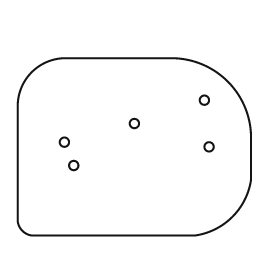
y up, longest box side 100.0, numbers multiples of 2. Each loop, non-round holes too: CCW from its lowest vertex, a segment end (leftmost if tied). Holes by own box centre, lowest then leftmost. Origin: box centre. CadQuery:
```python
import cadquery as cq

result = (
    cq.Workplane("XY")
    .moveTo(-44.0, -38.0)
    .lineTo(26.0, -38.0)
    .threePointArc((42.0, -30.0), (50.0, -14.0))
    .lineTo(50.0, 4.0)
    .threePointArc((40.0, 28.0), (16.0, 38.0))
    .lineTo(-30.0, 38.0)
    .threePointArc((-44.0, 32.0), (-50.0, 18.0))
    .lineTo(-50.0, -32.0)
    .threePointArc((-48.0, -36.0), (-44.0, -38.0))
    .close()
    .moveTo(-26.0, -8.0)
    .circle(2.0)
    .moveTo(32.0, 0.0)
    .circle(2.0)
    .moveTo(-30.0, 2.0)
    .circle(2.0)
    .moveTo(0.0, 10.0)
    .circle(2.0)
    .moveTo(30.0, 20.0)
    .circle(2.0)
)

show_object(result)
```